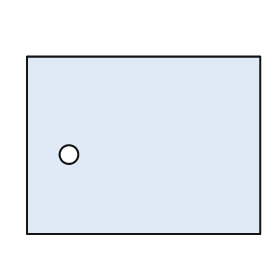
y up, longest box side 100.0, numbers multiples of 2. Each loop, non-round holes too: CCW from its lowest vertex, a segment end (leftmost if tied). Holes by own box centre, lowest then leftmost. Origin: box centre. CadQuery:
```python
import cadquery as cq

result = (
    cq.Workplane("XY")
    .moveTo(-50.0, -38.0)
    .lineTo(50.0, -38.0)
    .lineTo(50.0, 38.0)
    .lineTo(-50.0, 38.0)
    .close()
    .moveTo(-32.0, -4.0)
    .circle(4.0)
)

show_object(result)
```